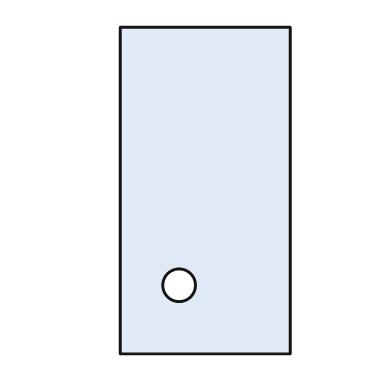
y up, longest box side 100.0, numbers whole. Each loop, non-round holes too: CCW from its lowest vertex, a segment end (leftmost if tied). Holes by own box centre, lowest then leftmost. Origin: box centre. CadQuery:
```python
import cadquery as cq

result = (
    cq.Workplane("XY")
    .moveTo(-26.0, -50.0)
    .lineTo(26.0, -50.0)
    .lineTo(26.0, 50.0)
    .lineTo(-26.0, 50.0)
    .close()
    .moveTo(-8.0, -29.0)
    .circle(5.0)
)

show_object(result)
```